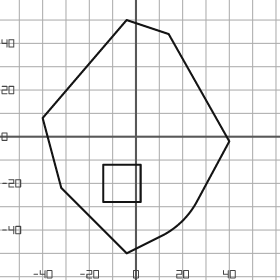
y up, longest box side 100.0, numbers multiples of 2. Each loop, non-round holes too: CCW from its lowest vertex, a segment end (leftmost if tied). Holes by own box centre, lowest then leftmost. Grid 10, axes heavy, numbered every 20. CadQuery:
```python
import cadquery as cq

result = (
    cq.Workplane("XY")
    .moveTo(-4.0, -50.0)
    .lineTo(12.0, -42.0)
    .threePointArc((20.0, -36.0), (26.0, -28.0))
    .lineTo(40.0, -2.0)
    .lineTo(14.0, 44.0)
    .lineTo(-4.0, 50.0)
    .lineTo(-40.0, 8.0)
    .lineTo(-32.0, -22.0)
    .close()
    .moveTo(-14.0, -28.0)
    .lineTo(2.0, -28.0)
    .lineTo(2.0, -12.0)
    .lineTo(-14.0, -12.0)
    .close()
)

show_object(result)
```